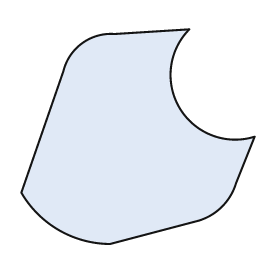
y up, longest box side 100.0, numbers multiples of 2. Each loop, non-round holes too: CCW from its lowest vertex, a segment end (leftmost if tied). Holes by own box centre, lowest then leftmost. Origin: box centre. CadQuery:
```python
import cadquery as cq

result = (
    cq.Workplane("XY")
    .moveTo(-12.0, -46.0)
    .lineTo(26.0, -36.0)
    .threePointArc((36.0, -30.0), (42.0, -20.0))
    .lineTo(50.0, 0.0)
    .threePointArc((18.0, 12.0), (22.0, 46.0))
    .lineTo(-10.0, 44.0)
    .threePointArc((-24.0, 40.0), (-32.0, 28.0))
    .lineTo(-50.0, -24.0)
    .threePointArc((-34.0, -40.0), (-12.0, -46.0))
    .close()
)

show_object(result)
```